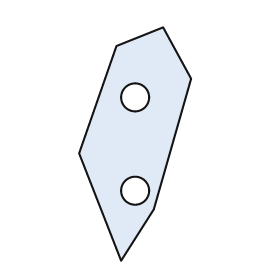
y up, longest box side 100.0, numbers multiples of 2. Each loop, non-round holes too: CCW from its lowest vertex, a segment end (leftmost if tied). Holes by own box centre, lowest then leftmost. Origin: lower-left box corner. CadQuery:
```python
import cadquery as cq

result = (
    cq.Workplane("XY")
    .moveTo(18.0, 0.0)
    .lineTo(32.0, 22.0)
    .lineTo(48.0, 78.0)
    .lineTo(36.0, 100.0)
    .lineTo(16.0, 92.0)
    .lineTo(0.0, 46.0)
    .close()
    .moveTo(24.0, 30.0)
    .circle(6.0)
    .moveTo(24.0, 70.0)
    .circle(6.0)
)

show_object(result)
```